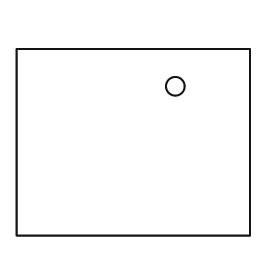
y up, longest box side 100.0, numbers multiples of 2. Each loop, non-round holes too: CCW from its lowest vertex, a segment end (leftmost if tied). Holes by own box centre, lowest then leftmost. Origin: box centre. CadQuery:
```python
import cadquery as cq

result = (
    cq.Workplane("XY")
    .moveTo(-50.0, -40.0)
    .lineTo(50.0, -40.0)
    .lineTo(50.0, 40.0)
    .lineTo(-50.0, 40.0)
    .close()
    .moveTo(18.0, 24.0)
    .circle(4.0)
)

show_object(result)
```